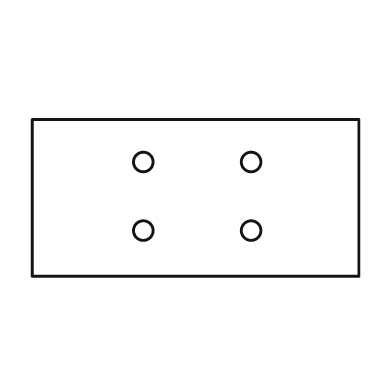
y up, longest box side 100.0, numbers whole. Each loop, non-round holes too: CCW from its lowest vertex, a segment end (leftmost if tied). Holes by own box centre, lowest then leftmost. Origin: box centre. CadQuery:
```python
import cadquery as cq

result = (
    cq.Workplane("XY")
    .moveTo(-50.0, -24.0)
    .lineTo(50.0, -24.0)
    .lineTo(50.0, 24.0)
    .lineTo(-50.0, 24.0)
    .close()
    .moveTo(-16.0, -10.0)
    .circle(3.0)
    .moveTo(17.0, -10.0)
    .circle(3.0)
    .moveTo(-16.0, 11.0)
    .circle(3.0)
    .moveTo(17.0, 11.0)
    .circle(3.0)
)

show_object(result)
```